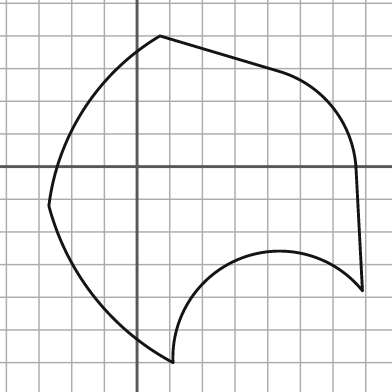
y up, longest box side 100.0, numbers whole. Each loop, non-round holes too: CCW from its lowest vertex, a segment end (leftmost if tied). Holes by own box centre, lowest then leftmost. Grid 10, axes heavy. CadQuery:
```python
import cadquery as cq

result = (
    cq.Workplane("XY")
    .moveTo(11.0, -60.0)
    .threePointArc((32.0, -28.0), (69.0, -38.0))
    .lineTo(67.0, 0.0)
    .threePointArc((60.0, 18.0), (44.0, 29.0))
    .lineTo(7.0, 40.0)
    .threePointArc((-16.0, 18.0), (-27.0, -12.0))
    .threePointArc((-13.0, -40.0), (11.0, -60.0))
    .close()
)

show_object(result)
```